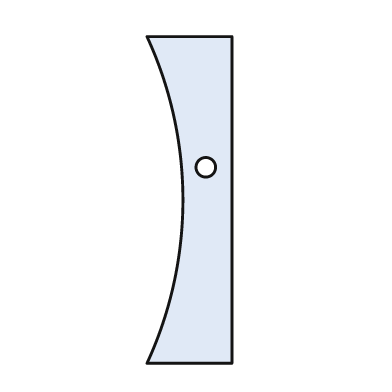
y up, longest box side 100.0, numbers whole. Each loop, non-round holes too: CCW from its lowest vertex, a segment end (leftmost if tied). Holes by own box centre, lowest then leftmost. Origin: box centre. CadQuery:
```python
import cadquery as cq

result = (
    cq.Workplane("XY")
    .moveTo(-13.0, -50.0)
    .lineTo(13.0, -50.0)
    .lineTo(13.0, 50.0)
    .lineTo(-13.0, 50.0)
    .threePointArc((-2.0, 0.0), (-13.0, -50.0))
    .close()
    .moveTo(5.0, 10.0)
    .circle(3.0)
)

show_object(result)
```